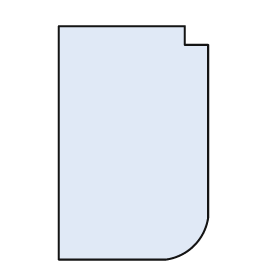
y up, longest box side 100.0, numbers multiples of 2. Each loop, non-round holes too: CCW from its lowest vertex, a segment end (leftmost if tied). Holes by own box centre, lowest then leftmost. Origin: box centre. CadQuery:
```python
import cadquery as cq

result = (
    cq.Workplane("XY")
    .moveTo(-32.0, -50.0)
    .lineTo(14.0, -50.0)
    .threePointArc((26.0, -44.0), (32.0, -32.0))
    .lineTo(32.0, 42.0)
    .lineTo(22.0, 42.0)
    .lineTo(22.0, 50.0)
    .lineTo(-32.0, 50.0)
    .close()
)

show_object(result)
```